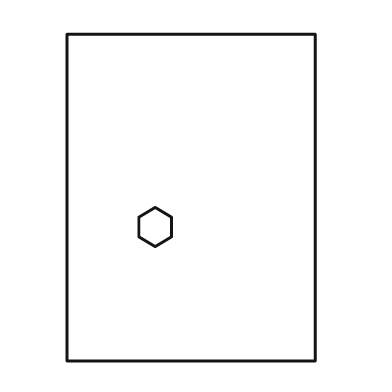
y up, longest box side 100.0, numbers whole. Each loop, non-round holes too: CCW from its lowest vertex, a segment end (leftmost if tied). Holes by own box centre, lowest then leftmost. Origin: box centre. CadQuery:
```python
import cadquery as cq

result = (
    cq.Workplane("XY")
    .moveTo(-38.0, -50.0)
    .lineTo(38.0, -50.0)
    .lineTo(38.0, 50.0)
    .lineTo(-38.0, 50.0)
    .close()
    .moveTo(-11.0, -15.0)
    .lineTo(-6.0, -12.0)
    .lineTo(-6.0, -6.0)
    .lineTo(-11.0, -3.0)
    .lineTo(-16.0, -6.0)
    .lineTo(-16.0, -12.0)
    .close()
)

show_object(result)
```